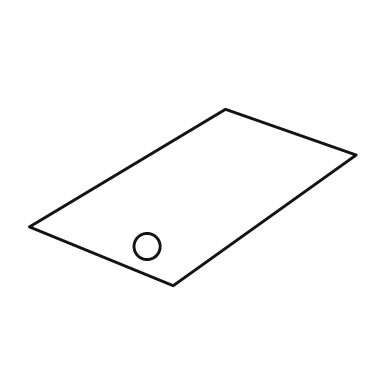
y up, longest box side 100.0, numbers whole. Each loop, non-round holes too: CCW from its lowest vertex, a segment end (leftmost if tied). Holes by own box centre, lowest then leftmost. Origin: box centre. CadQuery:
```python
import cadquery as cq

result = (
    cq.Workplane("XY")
    .moveTo(-6.0, -27.0)
    .lineTo(50.0, 13.0)
    .lineTo(10.0, 27.0)
    .lineTo(-50.0, -9.0)
    .close()
    .moveTo(-14.0, -15.0)
    .circle(4.0)
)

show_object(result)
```